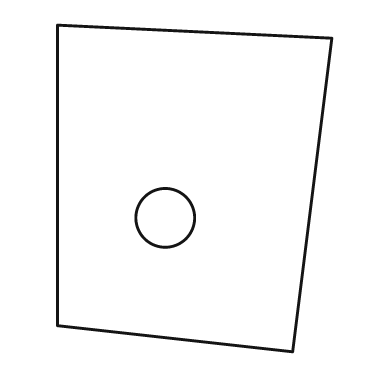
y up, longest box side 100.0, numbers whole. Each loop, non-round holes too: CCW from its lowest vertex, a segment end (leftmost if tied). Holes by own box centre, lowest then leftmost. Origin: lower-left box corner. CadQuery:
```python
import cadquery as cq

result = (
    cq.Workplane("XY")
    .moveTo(72.0, 0.0)
    .lineTo(84.0, 96.0)
    .lineTo(0.0, 100.0)
    .lineTo(0.0, 8.0)
    .close()
    .moveTo(33.0, 41.0)
    .circle(9.0)
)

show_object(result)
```